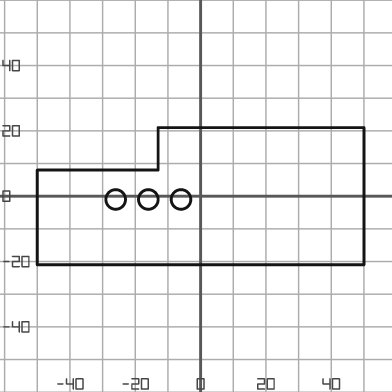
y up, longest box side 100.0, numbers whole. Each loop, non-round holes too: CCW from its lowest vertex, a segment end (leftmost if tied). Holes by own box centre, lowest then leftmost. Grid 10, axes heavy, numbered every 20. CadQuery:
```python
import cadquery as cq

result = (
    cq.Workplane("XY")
    .moveTo(-50.0, -21.0)
    .lineTo(50.0, -21.0)
    .lineTo(50.0, 21.0)
    .lineTo(-13.0, 21.0)
    .lineTo(-13.0, 8.0)
    .lineTo(-50.0, 8.0)
    .close()
    .moveTo(-26.0, -1.0)
    .circle(3.0)
    .moveTo(-16.0, -1.0)
    .circle(3.0)
    .moveTo(-6.0, -1.0)
    .circle(3.0)
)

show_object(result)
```